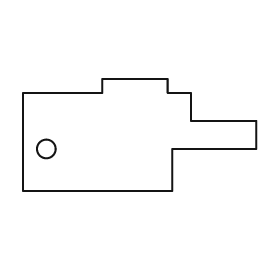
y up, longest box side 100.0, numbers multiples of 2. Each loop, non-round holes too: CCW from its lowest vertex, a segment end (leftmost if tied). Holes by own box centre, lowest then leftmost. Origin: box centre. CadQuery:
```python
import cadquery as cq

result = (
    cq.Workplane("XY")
    .moveTo(-50.0, -24.0)
    .lineTo(14.0, -24.0)
    .lineTo(14.0, -6.0)
    .lineTo(50.0, -6.0)
    .lineTo(50.0, 6.0)
    .lineTo(22.0, 6.0)
    .lineTo(22.0, 18.0)
    .lineTo(12.0, 18.0)
    .lineTo(12.0, 24.0)
    .lineTo(-16.0, 24.0)
    .lineTo(-16.0, 18.0)
    .lineTo(-50.0, 18.0)
    .close()
    .moveTo(-40.0, -6.0)
    .circle(4.0)
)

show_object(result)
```